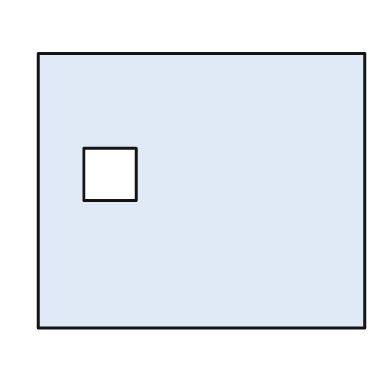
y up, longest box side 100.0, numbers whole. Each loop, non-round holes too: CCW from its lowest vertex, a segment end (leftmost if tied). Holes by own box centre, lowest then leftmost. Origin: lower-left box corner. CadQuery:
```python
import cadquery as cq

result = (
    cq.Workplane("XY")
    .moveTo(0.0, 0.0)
    .lineTo(100.0, 0.0)
    .lineTo(100.0, 84.0)
    .lineTo(0.0, 84.0)
    .close()
    .moveTo(14.0, 39.0)
    .lineTo(30.0, 39.0)
    .lineTo(30.0, 55.0)
    .lineTo(14.0, 55.0)
    .close()
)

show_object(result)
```